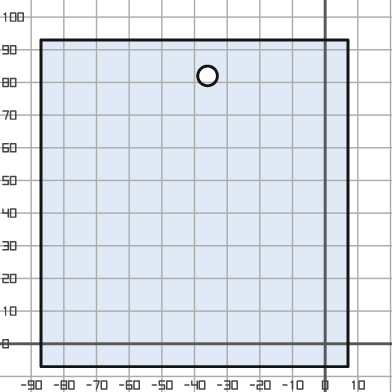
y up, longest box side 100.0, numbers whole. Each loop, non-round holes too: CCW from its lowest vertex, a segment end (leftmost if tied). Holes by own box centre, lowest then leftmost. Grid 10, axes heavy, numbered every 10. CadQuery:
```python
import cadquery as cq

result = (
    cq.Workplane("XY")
    .moveTo(-87.0, -7.0)
    .lineTo(7.0, -7.0)
    .lineTo(7.0, 93.0)
    .lineTo(-87.0, 93.0)
    .close()
    .moveTo(-36.0, 82.0)
    .circle(3.0)
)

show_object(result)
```